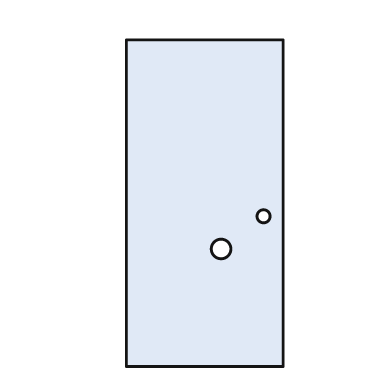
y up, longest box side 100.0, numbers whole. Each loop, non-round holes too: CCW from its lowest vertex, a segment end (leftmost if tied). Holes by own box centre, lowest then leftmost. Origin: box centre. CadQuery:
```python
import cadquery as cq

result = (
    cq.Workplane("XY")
    .moveTo(-24.0, -50.0)
    .lineTo(24.0, -50.0)
    .lineTo(24.0, 50.0)
    .lineTo(-24.0, 50.0)
    .close()
    .moveTo(5.0, -14.0)
    .circle(3.0)
    .moveTo(18.0, -4.0)
    .circle(2.0)
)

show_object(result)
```